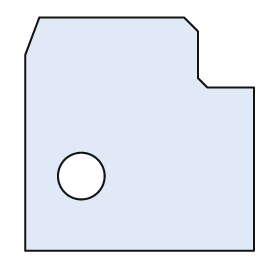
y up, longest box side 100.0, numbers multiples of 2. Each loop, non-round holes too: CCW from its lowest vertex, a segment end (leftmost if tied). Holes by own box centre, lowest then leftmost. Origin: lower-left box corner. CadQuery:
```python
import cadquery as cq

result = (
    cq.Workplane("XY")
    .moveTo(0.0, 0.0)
    .lineTo(98.0, 0.0)
    .lineTo(98.0, 70.0)
    .lineTo(78.0, 70.0)
    .lineTo(74.0, 74.0)
    .lineTo(74.0, 94.0)
    .lineTo(68.0, 100.0)
    .lineTo(6.0, 100.0)
    .lineTo(0.0, 84.0)
    .close()
    .moveTo(24.0, 32.0)
    .circle(10.0)
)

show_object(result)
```